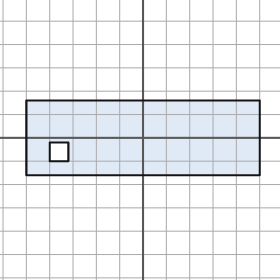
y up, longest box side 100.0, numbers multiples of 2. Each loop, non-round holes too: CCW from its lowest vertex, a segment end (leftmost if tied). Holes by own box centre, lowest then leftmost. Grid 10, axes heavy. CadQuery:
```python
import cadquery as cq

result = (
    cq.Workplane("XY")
    .moveTo(-50.0, -16.0)
    .lineTo(50.0, -16.0)
    .lineTo(50.0, 16.0)
    .lineTo(-50.0, 16.0)
    .close()
    .moveTo(-40.0, -10.0)
    .lineTo(-32.0, -10.0)
    .lineTo(-32.0, -2.0)
    .lineTo(-40.0, -2.0)
    .close()
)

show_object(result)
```